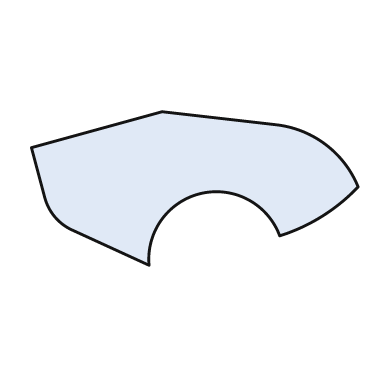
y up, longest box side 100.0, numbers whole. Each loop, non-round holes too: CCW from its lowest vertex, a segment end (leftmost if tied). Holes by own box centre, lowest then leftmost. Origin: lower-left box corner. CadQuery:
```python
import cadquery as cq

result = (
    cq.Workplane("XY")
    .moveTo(36.0, 0.0)
    .threePointArc((52.0, 22.0), (76.0, 9.0))
    .threePointArc((89.0, 15.0), (100.0, 24.0))
    .threePointArc((90.0, 37.0), (75.0, 43.0))
    .lineTo(40.0, 47.0)
    .lineTo(0.0, 36.0)
    .lineTo(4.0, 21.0)
    .threePointArc((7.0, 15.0), (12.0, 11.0))
    .close()
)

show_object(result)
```